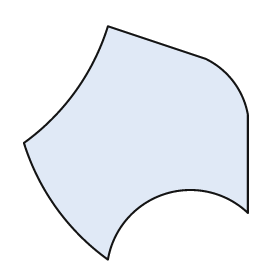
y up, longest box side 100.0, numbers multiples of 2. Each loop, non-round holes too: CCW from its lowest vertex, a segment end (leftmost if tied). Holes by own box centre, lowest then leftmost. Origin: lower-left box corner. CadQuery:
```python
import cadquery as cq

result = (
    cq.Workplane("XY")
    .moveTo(36.0, 0.0)
    .threePointArc((60.0, 28.0), (96.0, 20.0))
    .lineTo(96.0, 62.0)
    .threePointArc((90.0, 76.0), (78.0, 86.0))
    .lineTo(36.0, 100.0)
    .threePointArc((22.0, 72.0), (0.0, 50.0))
    .threePointArc((14.0, 22.0), (36.0, 0.0))
    .close()
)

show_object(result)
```